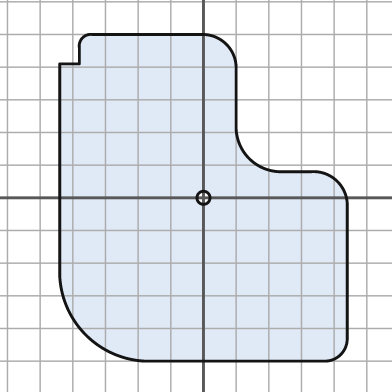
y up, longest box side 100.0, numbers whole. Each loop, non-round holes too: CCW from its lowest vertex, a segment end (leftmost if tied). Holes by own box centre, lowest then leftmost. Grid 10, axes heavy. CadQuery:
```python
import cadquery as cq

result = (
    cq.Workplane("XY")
    .moveTo(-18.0, -50.0)
    .lineTo(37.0, -50.0)
    .threePointArc((42.0, -48.0), (44.0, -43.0))
    .lineTo(44.0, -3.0)
    .threePointArc((41.0, 5.0), (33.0, 8.0))
    .lineTo(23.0, 8.0)
    .threePointArc((14.0, 12.0), (10.0, 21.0))
    .lineTo(10.0, 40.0)
    .threePointArc((7.0, 47.0), (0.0, 50.0))
    .lineTo(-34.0, 50.0)
    .threePointArc((-37.0, 49.0), (-38.0, 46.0))
    .lineTo(-38.0, 41.0)
    .lineTo(-44.0, 41.0)
    .lineTo(-44.0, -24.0)
    .threePointArc((-36.0, -42.0), (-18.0, -50.0))
    .close()
    .moveTo(0.0, 0.0)
    .circle(2.0)
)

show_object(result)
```